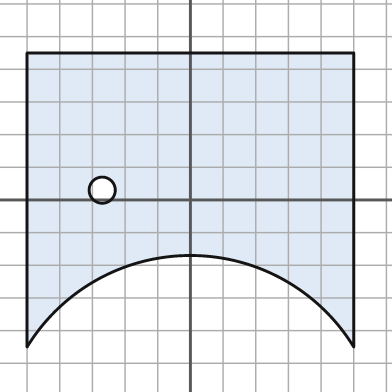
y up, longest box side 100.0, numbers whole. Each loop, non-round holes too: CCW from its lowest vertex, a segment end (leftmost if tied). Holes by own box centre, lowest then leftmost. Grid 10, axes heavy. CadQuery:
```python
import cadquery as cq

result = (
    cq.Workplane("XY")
    .moveTo(-50.0, -45.0)
    .threePointArc((0.0, -17.0), (50.0, -45.0))
    .lineTo(50.0, 45.0)
    .lineTo(-50.0, 45.0)
    .close()
    .moveTo(-27.0, 3.0)
    .circle(4.0)
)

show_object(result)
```